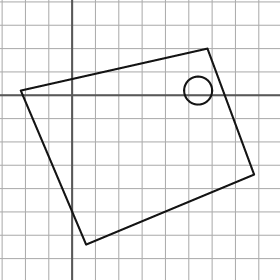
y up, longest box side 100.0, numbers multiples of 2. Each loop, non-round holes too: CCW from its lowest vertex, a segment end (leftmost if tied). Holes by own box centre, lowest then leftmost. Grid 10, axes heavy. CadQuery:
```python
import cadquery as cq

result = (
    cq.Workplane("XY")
    .moveTo(6.0, -64.0)
    .lineTo(78.0, -34.0)
    .lineTo(58.0, 20.0)
    .lineTo(-22.0, 2.0)
    .close()
    .moveTo(54.0, 2.0)
    .circle(6.0)
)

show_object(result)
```